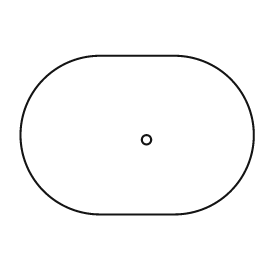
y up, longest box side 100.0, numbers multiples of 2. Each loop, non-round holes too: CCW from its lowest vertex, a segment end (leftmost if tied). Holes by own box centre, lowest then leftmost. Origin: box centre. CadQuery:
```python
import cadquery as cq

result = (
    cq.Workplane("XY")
    .moveTo(-16.0, -34.0)
    .lineTo(16.0, -34.0)
    .threePointArc((50.0, 0.0), (16.0, 34.0))
    .lineTo(-16.0, 34.0)
    .threePointArc((-50.0, 0.0), (-16.0, -34.0))
    .close()
    .moveTo(4.0, -2.0)
    .circle(2.0)
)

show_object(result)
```